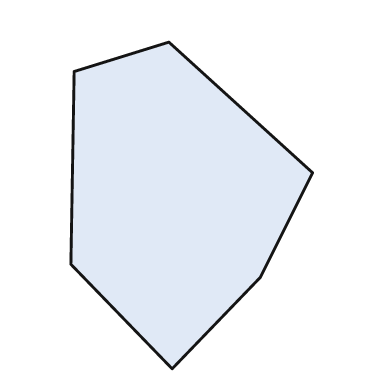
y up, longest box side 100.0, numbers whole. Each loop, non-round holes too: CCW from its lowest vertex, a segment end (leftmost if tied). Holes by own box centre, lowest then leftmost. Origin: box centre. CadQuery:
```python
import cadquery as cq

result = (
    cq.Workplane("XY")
    .moveTo(-6.0, -50.0)
    .lineTo(21.0, -22.0)
    .lineTo(37.0, 10.0)
    .lineTo(-7.0, 50.0)
    .lineTo(-36.0, 41.0)
    .lineTo(-37.0, -18.0)
    .close()
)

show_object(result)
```